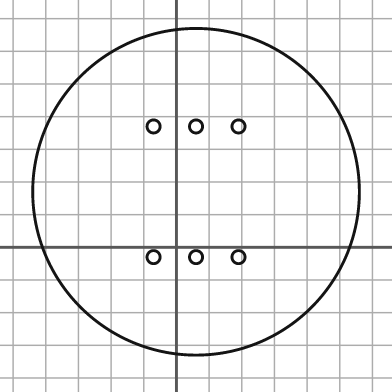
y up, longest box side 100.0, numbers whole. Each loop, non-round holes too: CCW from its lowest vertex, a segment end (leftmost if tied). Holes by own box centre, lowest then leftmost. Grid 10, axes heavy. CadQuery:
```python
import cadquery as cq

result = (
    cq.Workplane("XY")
    .moveTo(6.0, 17.0)
    .circle(50.0)
    .moveTo(-7.0, -3.0)
    .circle(2.0)
    .moveTo(6.0, -3.0)
    .circle(2.0)
    .moveTo(19.0, -3.0)
    .circle(2.0)
    .moveTo(-7.0, 37.0)
    .circle(2.0)
    .moveTo(6.0, 37.0)
    .circle(2.0)
    .moveTo(19.0, 37.0)
    .circle(2.0)
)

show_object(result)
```